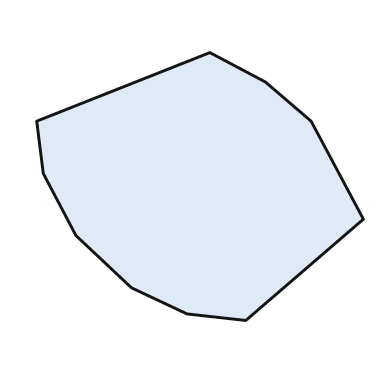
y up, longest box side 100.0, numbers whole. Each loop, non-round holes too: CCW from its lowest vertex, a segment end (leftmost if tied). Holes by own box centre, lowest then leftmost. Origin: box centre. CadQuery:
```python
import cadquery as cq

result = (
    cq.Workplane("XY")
    .moveTo(14.0, -41.0)
    .lineTo(50.0, -10.0)
    .lineTo(34.0, 20.0)
    .lineTo(20.0, 32.0)
    .lineTo(3.0, 41.0)
    .lineTo(-50.0, 20.0)
    .lineTo(-48.0, 4.0)
    .lineTo(-38.0, -15.0)
    .lineTo(-21.0, -31.0)
    .lineTo(-4.0, -39.0)
    .close()
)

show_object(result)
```